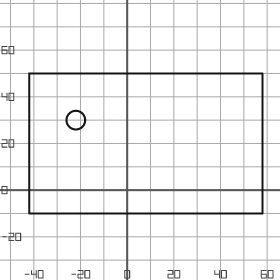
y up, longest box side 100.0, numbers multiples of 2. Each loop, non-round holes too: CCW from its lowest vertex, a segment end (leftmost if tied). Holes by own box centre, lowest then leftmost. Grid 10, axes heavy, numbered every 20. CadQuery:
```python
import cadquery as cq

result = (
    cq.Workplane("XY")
    .moveTo(-42.0, -10.0)
    .lineTo(58.0, -10.0)
    .lineTo(58.0, 50.0)
    .lineTo(-42.0, 50.0)
    .close()
    .moveTo(-22.0, 30.0)
    .circle(4.0)
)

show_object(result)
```